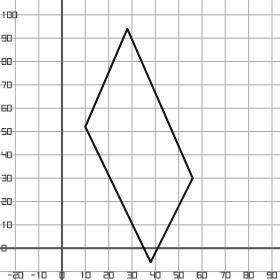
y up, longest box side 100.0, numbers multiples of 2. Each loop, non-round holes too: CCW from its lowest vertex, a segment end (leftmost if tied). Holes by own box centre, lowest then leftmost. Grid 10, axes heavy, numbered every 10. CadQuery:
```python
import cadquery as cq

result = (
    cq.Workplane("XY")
    .moveTo(38.0, -6.0)
    .lineTo(56.0, 30.0)
    .lineTo(28.0, 94.0)
    .lineTo(10.0, 52.0)
    .close()
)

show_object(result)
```